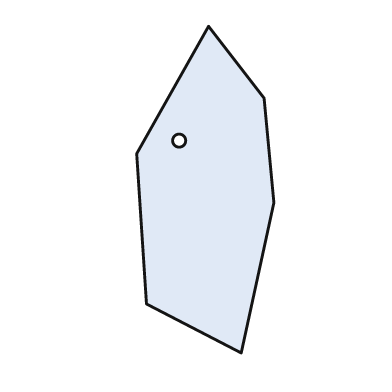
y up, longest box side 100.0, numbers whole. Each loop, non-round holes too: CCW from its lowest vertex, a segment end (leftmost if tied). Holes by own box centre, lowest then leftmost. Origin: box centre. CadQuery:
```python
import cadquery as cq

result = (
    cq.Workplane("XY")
    .moveTo(11.0, -50.0)
    .lineTo(21.0, -4.0)
    .lineTo(18.0, 28.0)
    .lineTo(1.0, 50.0)
    .lineTo(-21.0, 11.0)
    .lineTo(-18.0, -35.0)
    .close()
    .moveTo(-8.0, 15.0)
    .circle(2.0)
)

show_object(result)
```